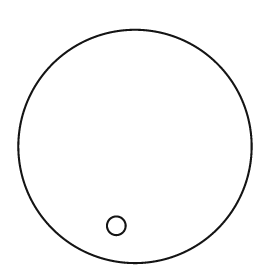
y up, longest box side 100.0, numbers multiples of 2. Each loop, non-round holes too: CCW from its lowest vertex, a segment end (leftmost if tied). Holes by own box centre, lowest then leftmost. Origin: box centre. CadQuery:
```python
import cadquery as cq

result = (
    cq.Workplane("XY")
    .moveTo(0.0, 0.0)
    .circle(50.0)
    .moveTo(-8.0, -34.0)
    .circle(4.0)
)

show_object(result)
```